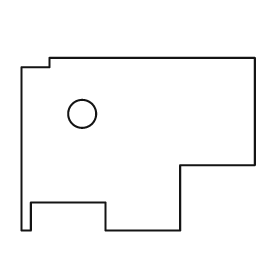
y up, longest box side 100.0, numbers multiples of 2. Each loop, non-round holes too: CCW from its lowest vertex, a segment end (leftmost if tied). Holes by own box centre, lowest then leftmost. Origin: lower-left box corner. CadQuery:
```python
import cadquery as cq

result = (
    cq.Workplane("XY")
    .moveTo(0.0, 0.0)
    .lineTo(4.0, 0.0)
    .lineTo(4.0, 12.0)
    .lineTo(36.0, 12.0)
    .lineTo(36.0, 0.0)
    .lineTo(68.0, 0.0)
    .lineTo(68.0, 28.0)
    .lineTo(100.0, 28.0)
    .lineTo(100.0, 74.0)
    .lineTo(12.0, 74.0)
    .lineTo(12.0, 70.0)
    .lineTo(0.0, 70.0)
    .close()
    .moveTo(26.0, 50.0)
    .circle(6.0)
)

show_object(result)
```